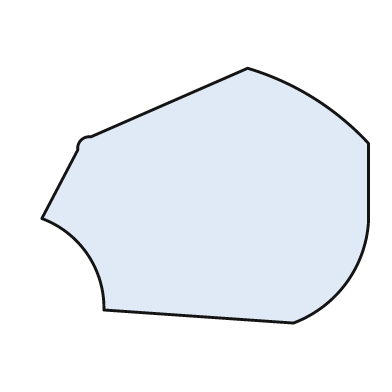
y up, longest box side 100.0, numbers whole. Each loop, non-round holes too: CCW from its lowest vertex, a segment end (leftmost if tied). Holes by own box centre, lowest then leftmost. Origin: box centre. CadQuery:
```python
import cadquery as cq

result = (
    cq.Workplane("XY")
    .moveTo(27.0, -39.0)
    .threePointArc((43.0, -27.0), (50.0, -8.0))
    .lineTo(50.0, 16.0)
    .threePointArc((33.0, 30.0), (13.0, 39.0))
    .lineTo(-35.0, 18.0)
    .threePointArc((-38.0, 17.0), (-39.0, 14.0))
    .lineTo(-50.0, -7.0)
    .threePointArc((-36.0, -18.0), (-31.0, -35.0))
    .close()
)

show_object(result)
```